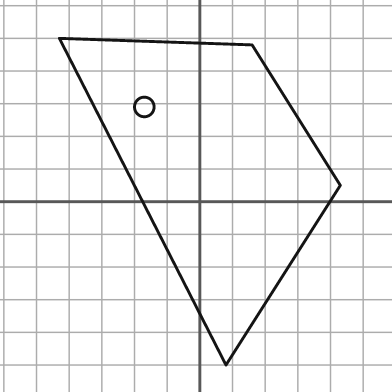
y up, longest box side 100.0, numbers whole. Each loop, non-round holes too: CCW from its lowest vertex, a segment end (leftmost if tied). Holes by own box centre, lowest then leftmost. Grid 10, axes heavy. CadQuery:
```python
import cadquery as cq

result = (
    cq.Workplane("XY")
    .moveTo(8.0, -50.0)
    .lineTo(43.0, 5.0)
    .lineTo(16.0, 48.0)
    .lineTo(-43.0, 50.0)
    .close()
    .moveTo(-17.0, 29.0)
    .circle(3.0)
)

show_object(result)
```